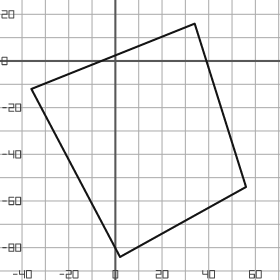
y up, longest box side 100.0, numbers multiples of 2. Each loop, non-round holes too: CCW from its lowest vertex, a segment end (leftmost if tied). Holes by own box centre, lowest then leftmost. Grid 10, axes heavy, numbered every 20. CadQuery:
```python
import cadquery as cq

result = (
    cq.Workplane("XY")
    .moveTo(2.0, -84.0)
    .lineTo(56.0, -54.0)
    .lineTo(34.0, 16.0)
    .lineTo(-36.0, -12.0)
    .close()
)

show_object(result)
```